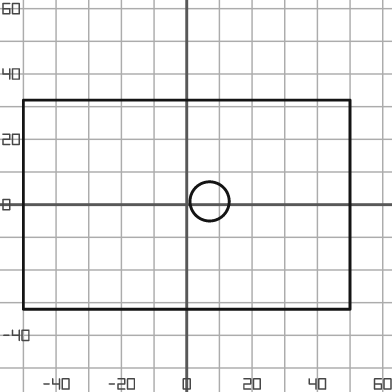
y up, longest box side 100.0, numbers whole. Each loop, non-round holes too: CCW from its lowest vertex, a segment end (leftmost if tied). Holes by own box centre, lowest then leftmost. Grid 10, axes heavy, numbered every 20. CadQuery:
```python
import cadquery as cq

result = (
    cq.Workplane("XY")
    .moveTo(-50.0, -32.0)
    .lineTo(50.0, -32.0)
    .lineTo(50.0, 32.0)
    .lineTo(-50.0, 32.0)
    .close()
    .moveTo(7.0, 1.0)
    .circle(6.0)
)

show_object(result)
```